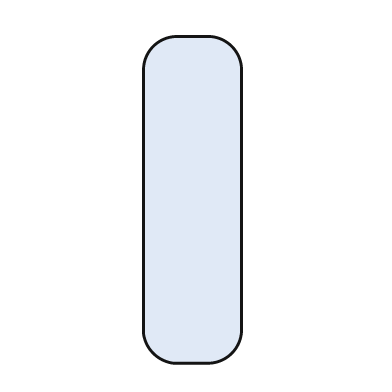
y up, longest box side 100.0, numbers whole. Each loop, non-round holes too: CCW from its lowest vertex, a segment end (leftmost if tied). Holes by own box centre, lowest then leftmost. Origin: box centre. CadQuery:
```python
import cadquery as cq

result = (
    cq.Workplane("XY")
    .moveTo(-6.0, -50.0)
    .lineTo(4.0, -50.0)
    .threePointArc((12.0, -47.0), (15.0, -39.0))
    .lineTo(15.0, 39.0)
    .threePointArc((12.0, 47.0), (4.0, 50.0))
    .lineTo(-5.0, 50.0)
    .threePointArc((-12.0, 47.0), (-15.0, 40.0))
    .lineTo(-15.0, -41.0)
    .threePointArc((-12.0, -47.0), (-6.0, -50.0))
    .close()
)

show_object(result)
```